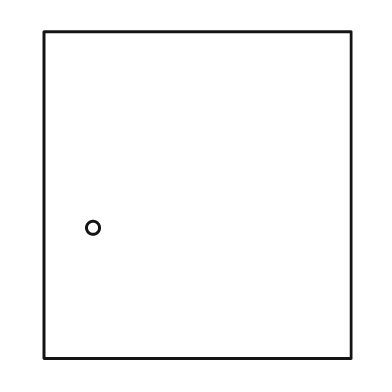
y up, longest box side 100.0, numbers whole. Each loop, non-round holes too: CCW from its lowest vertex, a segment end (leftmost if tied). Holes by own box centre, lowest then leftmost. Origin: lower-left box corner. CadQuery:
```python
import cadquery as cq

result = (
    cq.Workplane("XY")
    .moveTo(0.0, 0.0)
    .lineTo(94.0, 0.0)
    .lineTo(94.0, 100.0)
    .lineTo(0.0, 100.0)
    .close()
    .moveTo(15.0, 40.0)
    .circle(2.0)
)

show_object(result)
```